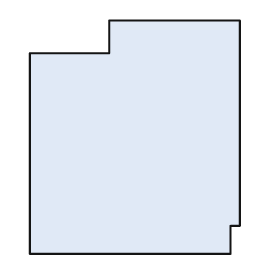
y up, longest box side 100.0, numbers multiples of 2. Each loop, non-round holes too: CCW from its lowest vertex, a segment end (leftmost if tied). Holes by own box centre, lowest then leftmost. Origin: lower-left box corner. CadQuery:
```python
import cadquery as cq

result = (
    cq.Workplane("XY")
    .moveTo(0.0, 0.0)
    .lineTo(86.0, 0.0)
    .lineTo(86.0, 12.0)
    .lineTo(90.0, 12.0)
    .lineTo(90.0, 100.0)
    .lineTo(34.0, 100.0)
    .lineTo(34.0, 86.0)
    .lineTo(0.0, 86.0)
    .close()
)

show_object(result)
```